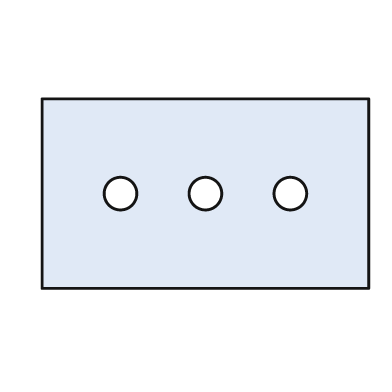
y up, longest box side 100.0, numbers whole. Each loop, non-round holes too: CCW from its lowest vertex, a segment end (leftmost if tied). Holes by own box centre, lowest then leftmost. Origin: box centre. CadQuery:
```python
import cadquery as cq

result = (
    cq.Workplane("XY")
    .moveTo(-50.0, -29.0)
    .lineTo(50.0, -29.0)
    .lineTo(50.0, 29.0)
    .lineTo(-50.0, 29.0)
    .close()
    .moveTo(-26.0, 0.0)
    .circle(5.0)
    .moveTo(0.0, 0.0)
    .circle(5.0)
    .moveTo(26.0, 0.0)
    .circle(5.0)
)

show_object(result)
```